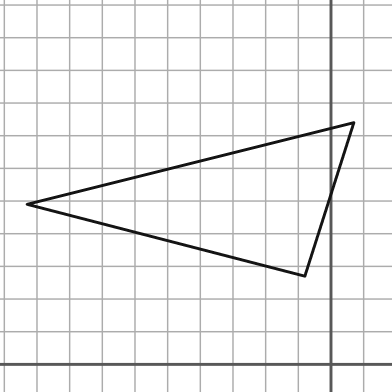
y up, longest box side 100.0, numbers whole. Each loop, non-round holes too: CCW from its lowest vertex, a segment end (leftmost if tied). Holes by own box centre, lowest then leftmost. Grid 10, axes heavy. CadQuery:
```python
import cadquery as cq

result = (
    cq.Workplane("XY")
    .moveTo(-8.0, 27.0)
    .lineTo(7.0, 74.0)
    .lineTo(-93.0, 49.0)
    .close()
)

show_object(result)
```